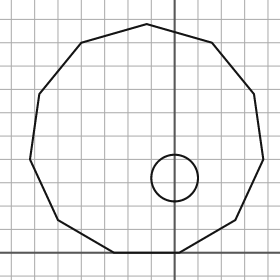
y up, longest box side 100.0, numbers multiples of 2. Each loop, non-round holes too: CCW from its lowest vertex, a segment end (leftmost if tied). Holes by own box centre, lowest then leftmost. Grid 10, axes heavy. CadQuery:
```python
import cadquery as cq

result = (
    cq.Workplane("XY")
    .moveTo(-26.0, 0.0)
    .lineTo(2.0, 0.0)
    .lineTo(26.0, 14.0)
    .lineTo(38.0, 40.0)
    .lineTo(34.0, 68.0)
    .lineTo(16.0, 90.0)
    .lineTo(-12.0, 98.0)
    .lineTo(-40.0, 90.0)
    .lineTo(-58.0, 68.0)
    .lineTo(-62.0, 40.0)
    .lineTo(-50.0, 14.0)
    .close()
    .moveTo(0.0, 32.0)
    .circle(10.0)
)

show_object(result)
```